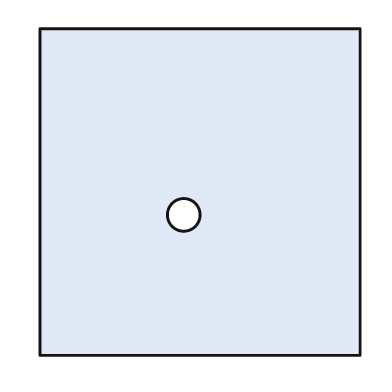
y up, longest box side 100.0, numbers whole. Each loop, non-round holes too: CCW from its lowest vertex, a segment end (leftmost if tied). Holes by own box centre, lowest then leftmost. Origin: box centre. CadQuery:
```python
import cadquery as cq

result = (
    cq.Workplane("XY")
    .moveTo(-49.0, -50.0)
    .lineTo(49.0, -50.0)
    .lineTo(49.0, 50.0)
    .lineTo(-49.0, 50.0)
    .close()
    .moveTo(-5.0, -7.0)
    .circle(5.0)
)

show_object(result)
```